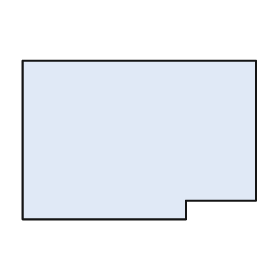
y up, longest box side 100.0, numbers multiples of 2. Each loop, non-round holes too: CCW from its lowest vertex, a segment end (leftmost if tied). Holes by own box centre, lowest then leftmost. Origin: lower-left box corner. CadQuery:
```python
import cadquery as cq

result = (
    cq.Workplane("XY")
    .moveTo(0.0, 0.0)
    .lineTo(70.0, 0.0)
    .lineTo(70.0, 8.0)
    .lineTo(100.0, 8.0)
    .lineTo(100.0, 68.0)
    .lineTo(0.0, 68.0)
    .close()
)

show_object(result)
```